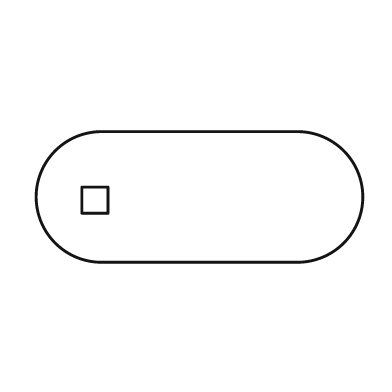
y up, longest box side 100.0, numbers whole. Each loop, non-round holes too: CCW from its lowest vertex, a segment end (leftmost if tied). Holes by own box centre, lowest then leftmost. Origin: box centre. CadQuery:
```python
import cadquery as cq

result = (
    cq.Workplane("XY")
    .moveTo(-30.0, -20.0)
    .lineTo(30.0, -20.0)
    .threePointArc((50.0, 0.0), (30.0, 20.0))
    .lineTo(-30.0, 20.0)
    .threePointArc((-50.0, 0.0), (-30.0, -20.0))
    .close()
    .moveTo(-36.0, -5.0)
    .lineTo(-28.0, -5.0)
    .lineTo(-28.0, 3.0)
    .lineTo(-36.0, 3.0)
    .close()
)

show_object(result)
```